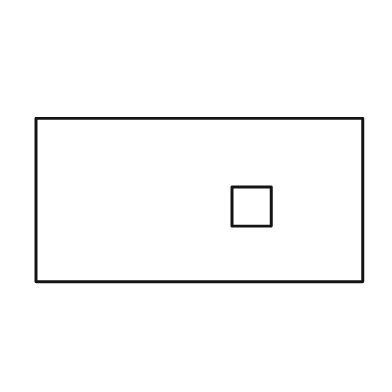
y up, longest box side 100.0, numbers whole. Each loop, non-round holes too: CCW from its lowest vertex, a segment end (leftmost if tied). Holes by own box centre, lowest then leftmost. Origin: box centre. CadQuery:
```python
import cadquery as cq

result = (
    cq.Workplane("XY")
    .moveTo(-50.0, -25.0)
    .lineTo(50.0, -25.0)
    .lineTo(50.0, 25.0)
    .lineTo(-50.0, 25.0)
    .close()
    .moveTo(10.0, -8.0)
    .lineTo(22.0, -8.0)
    .lineTo(22.0, 4.0)
    .lineTo(10.0, 4.0)
    .close()
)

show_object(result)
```